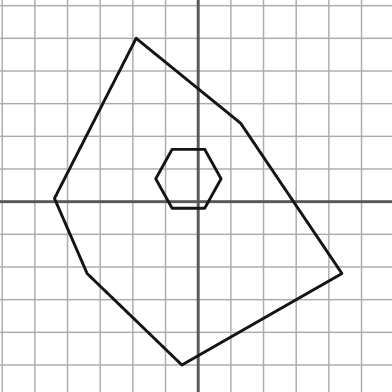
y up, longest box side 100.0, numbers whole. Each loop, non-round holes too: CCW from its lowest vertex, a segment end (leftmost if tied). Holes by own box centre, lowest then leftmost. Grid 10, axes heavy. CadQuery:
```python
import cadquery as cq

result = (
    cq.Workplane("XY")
    .moveTo(-5.0, -50.0)
    .lineTo(44.0, -22.0)
    .lineTo(13.0, 24.0)
    .lineTo(-19.0, 50.0)
    .lineTo(-44.0, 1.0)
    .lineTo(-34.0, -22.0)
    .close()
    .moveTo(-8.0, -2.0)
    .lineTo(2.0, -2.0)
    .lineTo(7.0, 7.0)
    .lineTo(2.0, 16.0)
    .lineTo(-8.0, 16.0)
    .lineTo(-13.0, 7.0)
    .close()
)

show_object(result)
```